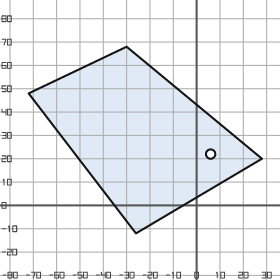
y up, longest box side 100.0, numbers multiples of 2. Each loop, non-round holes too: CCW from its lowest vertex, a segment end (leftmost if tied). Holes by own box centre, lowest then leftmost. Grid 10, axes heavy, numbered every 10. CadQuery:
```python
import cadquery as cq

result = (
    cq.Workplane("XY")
    .moveTo(-26.0, -12.0)
    .lineTo(28.0, 20.0)
    .lineTo(-30.0, 68.0)
    .lineTo(-72.0, 48.0)
    .close()
    .moveTo(6.0, 22.0)
    .circle(2.0)
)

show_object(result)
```